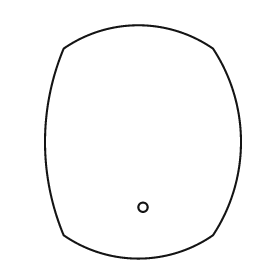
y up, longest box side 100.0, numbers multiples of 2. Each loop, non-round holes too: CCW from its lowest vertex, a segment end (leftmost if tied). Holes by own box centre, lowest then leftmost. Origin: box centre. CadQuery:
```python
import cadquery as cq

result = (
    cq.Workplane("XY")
    .moveTo(-34.0, -40.0)
    .threePointArc((-2.0, -50.0), (30.0, -40.0))
    .threePointArc((42.0, 0.0), (30.0, 40.0))
    .threePointArc((-2.0, 50.0), (-34.0, 40.0))
    .threePointArc((-42.0, 0.0), (-34.0, -40.0))
    .close()
    .moveTo(0.0, -28.0)
    .circle(2.0)
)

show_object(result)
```